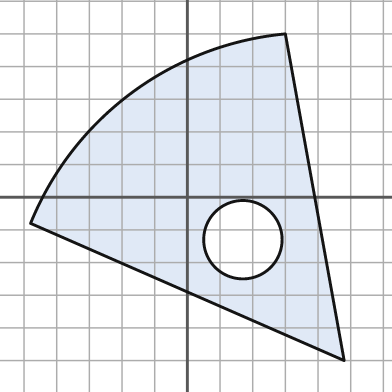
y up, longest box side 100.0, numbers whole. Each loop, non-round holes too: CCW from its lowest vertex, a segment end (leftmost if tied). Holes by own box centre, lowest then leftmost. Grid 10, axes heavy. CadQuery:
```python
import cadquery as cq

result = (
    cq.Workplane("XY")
    .moveTo(48.0, -50.0)
    .lineTo(30.0, 50.0)
    .threePointArc((-17.0, 32.0), (-48.0, -8.0))
    .close()
    .moveTo(17.0, -13.0)
    .circle(12.0)
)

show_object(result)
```